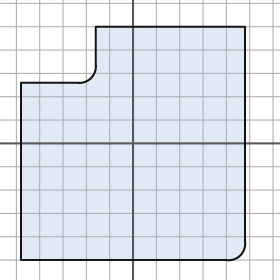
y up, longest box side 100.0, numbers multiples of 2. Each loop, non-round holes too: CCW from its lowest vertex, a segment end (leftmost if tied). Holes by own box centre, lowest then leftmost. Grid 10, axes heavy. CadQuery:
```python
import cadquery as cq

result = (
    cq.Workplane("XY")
    .moveTo(-48.0, -50.0)
    .lineTo(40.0, -50.0)
    .threePointArc((46.0, -48.0), (48.0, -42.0))
    .lineTo(48.0, 50.0)
    .lineTo(-16.0, 50.0)
    .lineTo(-16.0, 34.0)
    .threePointArc((-18.0, 28.0), (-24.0, 26.0))
    .lineTo(-48.0, 26.0)
    .close()
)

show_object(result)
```